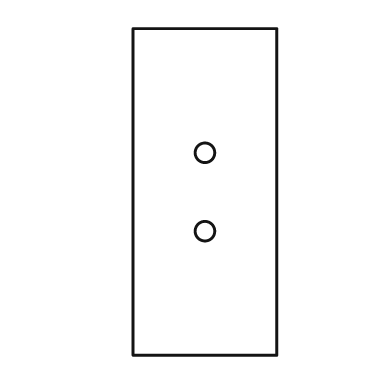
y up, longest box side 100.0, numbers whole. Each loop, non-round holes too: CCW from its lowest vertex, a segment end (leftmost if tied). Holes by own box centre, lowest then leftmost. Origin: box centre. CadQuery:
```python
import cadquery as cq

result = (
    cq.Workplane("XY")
    .moveTo(-22.0, -50.0)
    .lineTo(22.0, -50.0)
    .lineTo(22.0, 50.0)
    .lineTo(-22.0, 50.0)
    .close()
    .moveTo(0.0, -12.0)
    .circle(3.0)
    .moveTo(0.0, 12.0)
    .circle(3.0)
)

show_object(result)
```